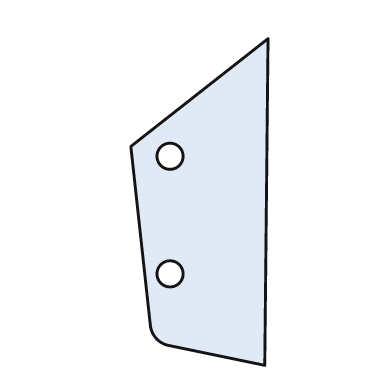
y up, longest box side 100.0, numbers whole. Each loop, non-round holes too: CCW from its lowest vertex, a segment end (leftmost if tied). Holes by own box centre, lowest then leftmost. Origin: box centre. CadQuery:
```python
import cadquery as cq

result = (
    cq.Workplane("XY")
    .moveTo(20.0, -50.0)
    .lineTo(21.0, 50.0)
    .lineTo(-21.0, 17.0)
    .lineTo(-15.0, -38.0)
    .threePointArc((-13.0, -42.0), (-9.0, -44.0))
    .close()
    .moveTo(-9.0, -22.0)
    .circle(4.0)
    .moveTo(-9.0, 14.0)
    .circle(4.0)
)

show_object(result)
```